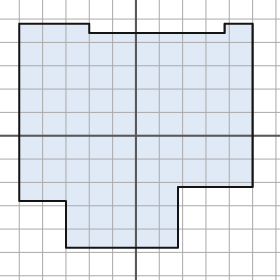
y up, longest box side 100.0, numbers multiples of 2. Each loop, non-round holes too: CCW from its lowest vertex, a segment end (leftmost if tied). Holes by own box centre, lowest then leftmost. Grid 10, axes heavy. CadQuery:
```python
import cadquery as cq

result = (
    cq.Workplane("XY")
    .moveTo(-30.0, -48.0)
    .lineTo(18.0, -48.0)
    .lineTo(18.0, -22.0)
    .lineTo(50.0, -22.0)
    .lineTo(50.0, 48.0)
    .lineTo(38.0, 48.0)
    .lineTo(38.0, 44.0)
    .lineTo(-20.0, 44.0)
    .lineTo(-20.0, 48.0)
    .lineTo(-50.0, 48.0)
    .lineTo(-50.0, -28.0)
    .lineTo(-30.0, -28.0)
    .close()
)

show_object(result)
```